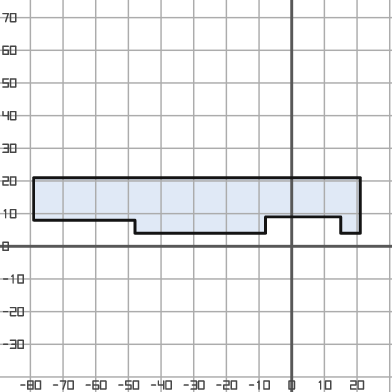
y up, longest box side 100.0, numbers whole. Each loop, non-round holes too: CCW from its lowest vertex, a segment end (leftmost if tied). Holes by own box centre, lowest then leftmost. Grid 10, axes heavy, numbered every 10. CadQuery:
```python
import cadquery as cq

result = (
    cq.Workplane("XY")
    .moveTo(-48.0, 4.0)
    .lineTo(-8.0, 4.0)
    .lineTo(-8.0, 9.0)
    .lineTo(15.0, 9.0)
    .lineTo(15.0, 4.0)
    .lineTo(21.0, 4.0)
    .lineTo(21.0, 21.0)
    .lineTo(-79.0, 21.0)
    .lineTo(-79.0, 8.0)
    .lineTo(-48.0, 8.0)
    .close()
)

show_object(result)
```